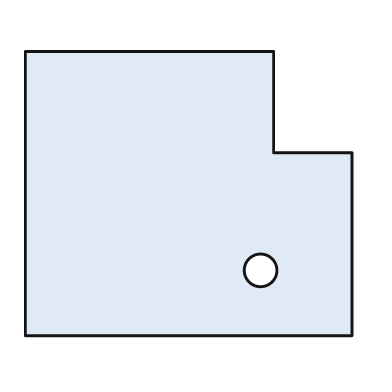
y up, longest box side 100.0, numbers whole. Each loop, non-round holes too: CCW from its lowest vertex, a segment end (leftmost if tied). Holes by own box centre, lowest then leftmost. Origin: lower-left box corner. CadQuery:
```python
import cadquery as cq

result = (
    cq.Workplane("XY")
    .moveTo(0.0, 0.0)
    .lineTo(100.0, 0.0)
    .lineTo(100.0, 56.0)
    .lineTo(76.0, 56.0)
    .lineTo(76.0, 87.0)
    .lineTo(0.0, 87.0)
    .close()
    .moveTo(72.0, 20.0)
    .circle(5.0)
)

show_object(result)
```